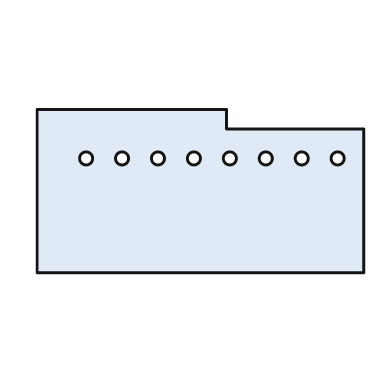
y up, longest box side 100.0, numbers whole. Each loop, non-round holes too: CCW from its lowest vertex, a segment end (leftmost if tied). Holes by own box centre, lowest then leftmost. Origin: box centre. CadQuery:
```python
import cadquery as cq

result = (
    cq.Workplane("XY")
    .moveTo(-50.0, -25.0)
    .lineTo(50.0, -25.0)
    .lineTo(50.0, 19.0)
    .lineTo(8.0, 19.0)
    .lineTo(8.0, 25.0)
    .lineTo(-50.0, 25.0)
    .close()
    .moveTo(-35.0, 10.0)
    .circle(2.0)
    .moveTo(-24.0, 10.0)
    .circle(2.0)
    .moveTo(-13.0, 10.0)
    .circle(2.0)
    .moveTo(-2.0, 10.0)
    .circle(2.0)
    .moveTo(9.0, 10.0)
    .circle(2.0)
    .moveTo(20.0, 10.0)
    .circle(2.0)
    .moveTo(31.0, 10.0)
    .circle(2.0)
    .moveTo(42.0, 10.0)
    .circle(2.0)
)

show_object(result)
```